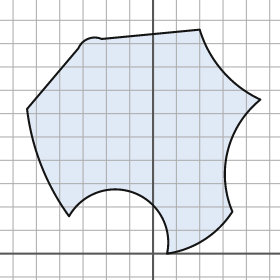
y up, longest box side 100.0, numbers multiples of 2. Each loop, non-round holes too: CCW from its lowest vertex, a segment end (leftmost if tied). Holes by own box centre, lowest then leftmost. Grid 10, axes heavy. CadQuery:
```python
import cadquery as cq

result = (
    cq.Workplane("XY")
    .moveTo(6.0, 0.0)
    .threePointArc((22.0, 6.0), (34.0, 18.0))
    .threePointArc((32.0, 44.0), (46.0, 66.0))
    .threePointArc((30.0, 78.0), (20.0, 96.0))
    .lineTo(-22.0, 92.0)
    .threePointArc((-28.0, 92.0), (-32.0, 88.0))
    .lineTo(-54.0, 62.0)
    .threePointArc((-48.0, 38.0), (-36.0, 16.0))
    .threePointArc((-8.0, 26.0), (6.0, 0.0))
    .close()
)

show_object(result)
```